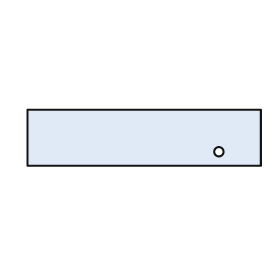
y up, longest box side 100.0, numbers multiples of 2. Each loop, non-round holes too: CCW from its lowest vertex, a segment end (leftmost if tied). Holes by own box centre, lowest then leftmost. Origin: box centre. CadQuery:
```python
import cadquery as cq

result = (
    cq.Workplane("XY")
    .moveTo(-50.0, -12.0)
    .lineTo(50.0, -12.0)
    .lineTo(50.0, 12.0)
    .lineTo(-50.0, 12.0)
    .close()
    .moveTo(32.0, -6.0)
    .circle(2.0)
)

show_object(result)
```